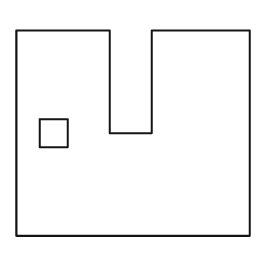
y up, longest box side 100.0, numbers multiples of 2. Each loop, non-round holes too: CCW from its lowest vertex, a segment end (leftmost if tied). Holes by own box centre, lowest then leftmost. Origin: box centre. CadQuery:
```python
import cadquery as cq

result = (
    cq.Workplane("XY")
    .moveTo(-50.0, -44.0)
    .lineTo(50.0, -44.0)
    .lineTo(50.0, 44.0)
    .lineTo(8.0, 44.0)
    .lineTo(8.0, 0.0)
    .lineTo(-10.0, 0.0)
    .lineTo(-10.0, 44.0)
    .lineTo(-50.0, 44.0)
    .close()
    .moveTo(-40.0, -6.0)
    .lineTo(-28.0, -6.0)
    .lineTo(-28.0, 6.0)
    .lineTo(-40.0, 6.0)
    .close()
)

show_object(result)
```